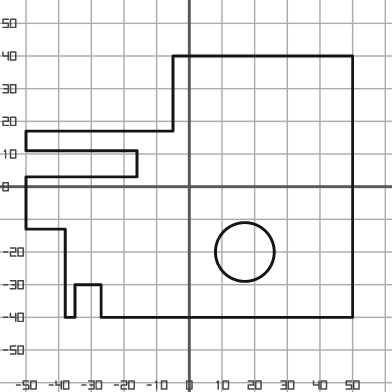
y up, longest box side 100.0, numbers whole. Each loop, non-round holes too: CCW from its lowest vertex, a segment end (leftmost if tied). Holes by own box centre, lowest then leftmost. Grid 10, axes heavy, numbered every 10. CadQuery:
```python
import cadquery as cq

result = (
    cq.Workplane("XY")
    .moveTo(-38.0, -40.0)
    .lineTo(-35.0, -40.0)
    .lineTo(-35.0, -30.0)
    .lineTo(-27.0, -30.0)
    .lineTo(-27.0, -40.0)
    .lineTo(50.0, -40.0)
    .lineTo(50.0, 40.0)
    .lineTo(-5.0, 40.0)
    .lineTo(-5.0, 17.0)
    .lineTo(-50.0, 17.0)
    .lineTo(-50.0, 11.0)
    .lineTo(-16.0, 11.0)
    .lineTo(-16.0, 3.0)
    .lineTo(-50.0, 3.0)
    .lineTo(-50.0, -13.0)
    .lineTo(-38.0, -13.0)
    .close()
    .moveTo(17.0, -20.0)
    .circle(9.0)
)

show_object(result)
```